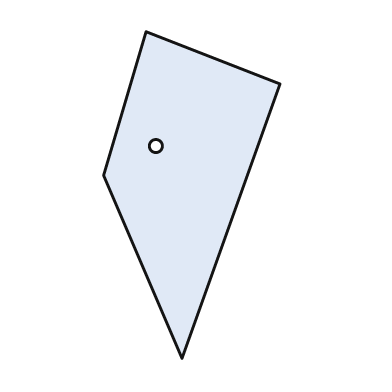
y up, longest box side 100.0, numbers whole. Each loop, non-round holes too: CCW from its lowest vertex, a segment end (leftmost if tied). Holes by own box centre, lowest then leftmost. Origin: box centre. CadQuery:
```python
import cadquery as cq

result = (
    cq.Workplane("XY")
    .moveTo(-3.0, -50.0)
    .lineTo(27.0, 34.0)
    .lineTo(-14.0, 50.0)
    .lineTo(-27.0, 6.0)
    .close()
    .moveTo(-11.0, 15.0)
    .circle(2.0)
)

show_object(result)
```